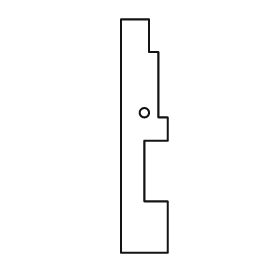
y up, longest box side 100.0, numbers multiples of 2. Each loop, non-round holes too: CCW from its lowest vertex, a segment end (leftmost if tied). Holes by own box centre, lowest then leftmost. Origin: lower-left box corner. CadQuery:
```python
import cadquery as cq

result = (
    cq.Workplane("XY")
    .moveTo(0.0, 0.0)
    .lineTo(20.0, 0.0)
    .lineTo(20.0, 22.0)
    .lineTo(10.0, 22.0)
    .lineTo(10.0, 48.0)
    .lineTo(20.0, 48.0)
    .lineTo(20.0, 58.0)
    .lineTo(16.0, 58.0)
    .lineTo(16.0, 86.0)
    .lineTo(12.0, 86.0)
    .lineTo(12.0, 100.0)
    .lineTo(0.0, 100.0)
    .close()
    .moveTo(10.0, 60.0)
    .circle(2.0)
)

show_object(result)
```